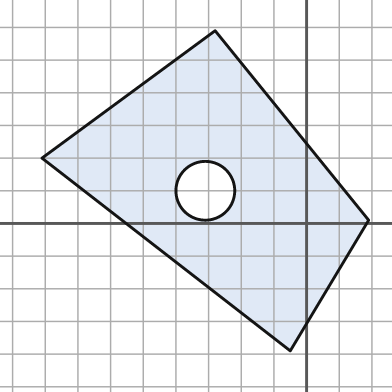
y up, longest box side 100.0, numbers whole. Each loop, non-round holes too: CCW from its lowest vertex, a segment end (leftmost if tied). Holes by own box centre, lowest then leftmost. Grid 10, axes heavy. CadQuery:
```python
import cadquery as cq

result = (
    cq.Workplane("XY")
    .moveTo(-5.0, -39.0)
    .lineTo(19.0, 1.0)
    .lineTo(-28.0, 59.0)
    .lineTo(-81.0, 20.0)
    .close()
    .moveTo(-31.0, 10.0)
    .circle(9.0)
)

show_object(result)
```